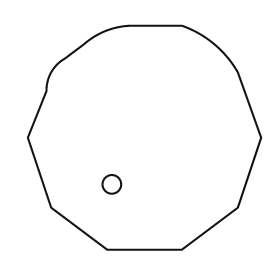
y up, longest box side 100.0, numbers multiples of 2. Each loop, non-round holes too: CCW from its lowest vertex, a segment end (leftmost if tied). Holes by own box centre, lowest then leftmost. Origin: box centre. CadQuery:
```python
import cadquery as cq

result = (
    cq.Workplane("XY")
    .moveTo(-16.0, -48.0)
    .lineTo(16.0, -48.0)
    .lineTo(40.0, -30.0)
    .lineTo(50.0, 0.0)
    .lineTo(40.0, 28.0)
    .threePointArc((30.0, 40.0), (16.0, 48.0))
    .lineTo(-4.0, 48.0)
    .threePointArc((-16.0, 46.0), (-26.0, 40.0))
    .lineTo(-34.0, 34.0)
    .threePointArc((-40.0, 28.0), (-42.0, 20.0))
    .lineTo(-50.0, 0.0)
    .lineTo(-40.0, -30.0)
    .close()
    .moveTo(-14.0, -20.0)
    .circle(4.0)
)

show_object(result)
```